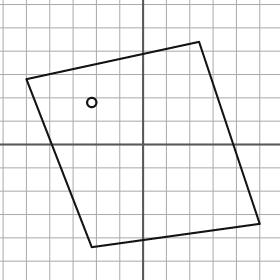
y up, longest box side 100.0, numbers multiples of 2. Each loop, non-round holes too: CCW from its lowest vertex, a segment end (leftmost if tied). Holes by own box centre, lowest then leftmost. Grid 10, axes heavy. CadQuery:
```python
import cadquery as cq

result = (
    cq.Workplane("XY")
    .moveTo(-22.0, -44.0)
    .lineTo(50.0, -34.0)
    .lineTo(24.0, 44.0)
    .lineTo(-50.0, 28.0)
    .close()
    .moveTo(-22.0, 18.0)
    .circle(2.0)
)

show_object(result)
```